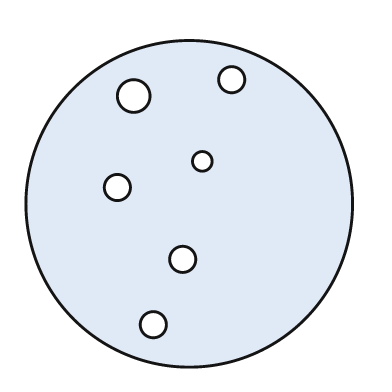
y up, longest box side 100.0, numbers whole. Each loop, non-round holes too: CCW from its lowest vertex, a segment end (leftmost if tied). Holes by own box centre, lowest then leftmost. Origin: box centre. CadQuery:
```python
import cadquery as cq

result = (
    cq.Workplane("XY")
    .moveTo(0.0, 0.0)
    .circle(50.0)
    .moveTo(-11.0, -37.0)
    .circle(4.0)
    .moveTo(-2.0, -17.0)
    .circle(4.0)
    .moveTo(-22.0, 5.0)
    .circle(4.0)
    .moveTo(4.0, 13.0)
    .circle(3.0)
    .moveTo(-17.0, 33.0)
    .circle(5.0)
    .moveTo(13.0, 38.0)
    .circle(4.0)
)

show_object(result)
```